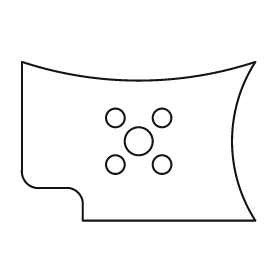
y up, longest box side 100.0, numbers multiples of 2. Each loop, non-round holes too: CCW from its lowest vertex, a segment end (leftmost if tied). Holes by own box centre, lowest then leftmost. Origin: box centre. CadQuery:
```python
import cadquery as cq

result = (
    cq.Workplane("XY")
    .moveTo(-24.0, -34.0)
    .lineTo(50.0, -34.0)
    .threePointArc((40.0, 0.0), (50.0, 34.0))
    .threePointArc((0.0, 26.0), (-50.0, 34.0))
    .lineTo(-50.0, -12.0)
    .threePointArc((-48.0, -18.0), (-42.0, -20.0))
    .lineTo(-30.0, -20.0)
    .threePointArc((-26.0, -22.0), (-24.0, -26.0))
    .close()
    .moveTo(-10.0, -10.0)
    .circle(4.0)
    .moveTo(10.0, -10.0)
    .circle(4.0)
    .moveTo(0.0, 0.0)
    .circle(6.0)
    .moveTo(-10.0, 10.0)
    .circle(4.0)
    .moveTo(10.0, 10.0)
    .circle(4.0)
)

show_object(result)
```